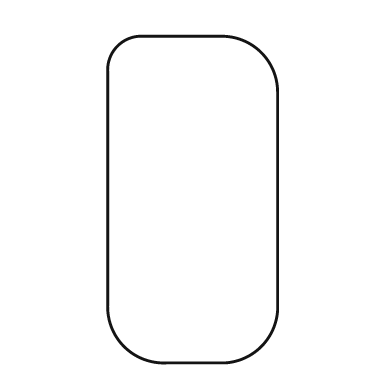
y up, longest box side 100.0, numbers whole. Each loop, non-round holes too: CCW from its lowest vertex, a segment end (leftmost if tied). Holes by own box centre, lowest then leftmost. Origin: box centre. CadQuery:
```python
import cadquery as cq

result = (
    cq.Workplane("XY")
    .moveTo(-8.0, -50.0)
    .lineTo(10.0, -50.0)
    .threePointArc((21.0, -45.0), (26.0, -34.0))
    .lineTo(26.0, 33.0)
    .threePointArc((21.0, 45.0), (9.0, 50.0))
    .lineTo(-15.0, 50.0)
    .threePointArc((-23.0, 47.0), (-26.0, 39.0))
    .lineTo(-26.0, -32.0)
    .threePointArc((-21.0, -45.0), (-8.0, -50.0))
    .close()
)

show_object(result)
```